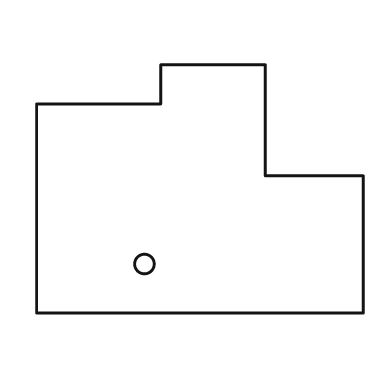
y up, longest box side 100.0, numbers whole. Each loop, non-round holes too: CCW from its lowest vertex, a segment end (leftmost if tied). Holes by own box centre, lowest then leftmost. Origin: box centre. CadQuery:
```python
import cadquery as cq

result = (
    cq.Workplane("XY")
    .moveTo(-50.0, -38.0)
    .lineTo(50.0, -38.0)
    .lineTo(50.0, 4.0)
    .lineTo(20.0, 4.0)
    .lineTo(20.0, 38.0)
    .lineTo(-12.0, 38.0)
    .lineTo(-12.0, 26.0)
    .lineTo(-50.0, 26.0)
    .close()
    .moveTo(-17.0, -23.0)
    .circle(3.0)
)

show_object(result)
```